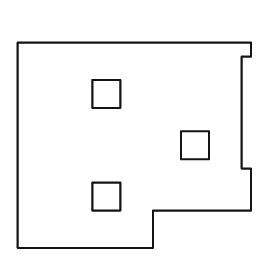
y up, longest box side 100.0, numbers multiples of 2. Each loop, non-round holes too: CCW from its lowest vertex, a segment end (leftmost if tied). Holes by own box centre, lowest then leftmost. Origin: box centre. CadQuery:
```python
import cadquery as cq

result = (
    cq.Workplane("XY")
    .moveTo(-50.0, -44.0)
    .lineTo(8.0, -44.0)
    .lineTo(8.0, -28.0)
    .lineTo(50.0, -28.0)
    .lineTo(50.0, -10.0)
    .lineTo(46.0, -10.0)
    .lineTo(46.0, 38.0)
    .lineTo(50.0, 38.0)
    .lineTo(50.0, 44.0)
    .lineTo(-50.0, 44.0)
    .close()
    .moveTo(-18.0, -28.0)
    .lineTo(-6.0, -28.0)
    .lineTo(-6.0, -16.0)
    .lineTo(-18.0, -16.0)
    .close()
    .moveTo(20.0, -6.0)
    .lineTo(32.0, -6.0)
    .lineTo(32.0, 6.0)
    .lineTo(20.0, 6.0)
    .close()
    .moveTo(-18.0, 16.0)
    .lineTo(-6.0, 16.0)
    .lineTo(-6.0, 28.0)
    .lineTo(-18.0, 28.0)
    .close()
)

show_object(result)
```